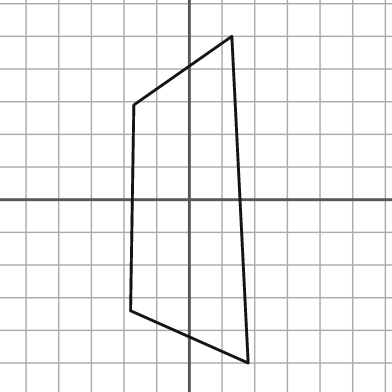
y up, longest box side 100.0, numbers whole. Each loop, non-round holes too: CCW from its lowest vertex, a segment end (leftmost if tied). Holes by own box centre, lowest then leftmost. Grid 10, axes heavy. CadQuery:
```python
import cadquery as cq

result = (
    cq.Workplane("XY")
    .moveTo(18.0, -50.0)
    .lineTo(13.0, 50.0)
    .lineTo(-17.0, 29.0)
    .lineTo(-18.0, -34.0)
    .close()
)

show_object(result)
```